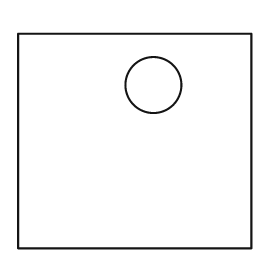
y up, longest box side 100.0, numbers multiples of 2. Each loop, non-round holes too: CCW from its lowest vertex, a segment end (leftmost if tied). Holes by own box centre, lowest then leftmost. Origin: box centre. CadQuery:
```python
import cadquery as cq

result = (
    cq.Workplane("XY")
    .moveTo(-50.0, -46.0)
    .lineTo(50.0, -46.0)
    .lineTo(50.0, 46.0)
    .lineTo(-50.0, 46.0)
    .close()
    .moveTo(8.0, 24.0)
    .circle(12.0)
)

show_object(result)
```